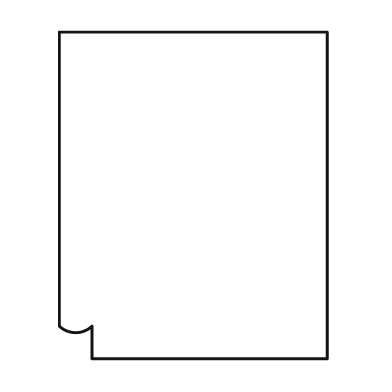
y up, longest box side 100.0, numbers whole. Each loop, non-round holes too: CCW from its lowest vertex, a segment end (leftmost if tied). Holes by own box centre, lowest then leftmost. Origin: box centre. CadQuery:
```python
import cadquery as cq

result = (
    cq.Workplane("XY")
    .moveTo(-31.0, -50.0)
    .lineTo(41.0, -50.0)
    .lineTo(41.0, 50.0)
    .lineTo(-41.0, 50.0)
    .lineTo(-41.0, -40.0)
    .threePointArc((-36.0, -42.0), (-31.0, -40.0))
    .close()
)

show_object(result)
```